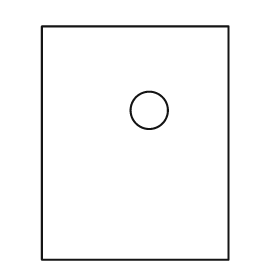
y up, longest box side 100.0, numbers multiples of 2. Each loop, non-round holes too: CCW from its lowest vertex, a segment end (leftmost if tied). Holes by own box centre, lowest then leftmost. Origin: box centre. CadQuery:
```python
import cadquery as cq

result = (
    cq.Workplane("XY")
    .moveTo(-40.0, -50.0)
    .lineTo(40.0, -50.0)
    .lineTo(40.0, 50.0)
    .lineTo(-40.0, 50.0)
    .close()
    .moveTo(6.0, 14.0)
    .circle(8.0)
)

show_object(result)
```